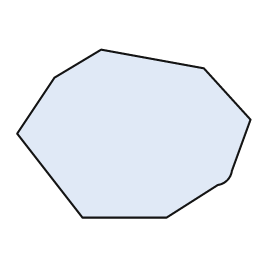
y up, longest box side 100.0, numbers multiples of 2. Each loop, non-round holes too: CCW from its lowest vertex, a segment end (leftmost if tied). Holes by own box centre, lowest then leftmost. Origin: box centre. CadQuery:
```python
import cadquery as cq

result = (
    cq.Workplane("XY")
    .moveTo(-22.0, -36.0)
    .lineTo(14.0, -36.0)
    .lineTo(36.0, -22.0)
    .threePointArc((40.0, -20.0), (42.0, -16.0))
    .lineTo(50.0, 6.0)
    .lineTo(30.0, 28.0)
    .lineTo(-14.0, 36.0)
    .lineTo(-34.0, 24.0)
    .lineTo(-50.0, 0.0)
    .close()
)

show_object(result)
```